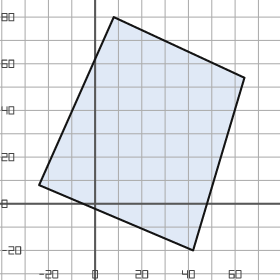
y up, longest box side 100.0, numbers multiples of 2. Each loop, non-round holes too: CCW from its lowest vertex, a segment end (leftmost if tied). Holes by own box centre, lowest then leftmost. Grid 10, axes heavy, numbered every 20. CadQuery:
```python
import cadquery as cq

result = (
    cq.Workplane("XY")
    .moveTo(42.0, -20.0)
    .lineTo(64.0, 54.0)
    .lineTo(8.0, 80.0)
    .lineTo(-24.0, 8.0)
    .close()
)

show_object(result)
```